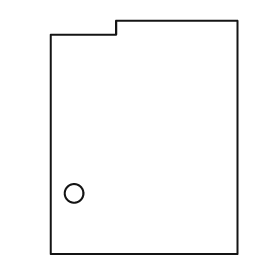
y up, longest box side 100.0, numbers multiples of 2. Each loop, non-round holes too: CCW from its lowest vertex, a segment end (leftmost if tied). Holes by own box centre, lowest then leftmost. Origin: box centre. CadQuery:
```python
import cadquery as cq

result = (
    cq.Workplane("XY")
    .moveTo(-40.0, -50.0)
    .lineTo(40.0, -50.0)
    .lineTo(40.0, 50.0)
    .lineTo(-12.0, 50.0)
    .lineTo(-12.0, 44.0)
    .lineTo(-40.0, 44.0)
    .close()
    .moveTo(-30.0, -24.0)
    .circle(4.0)
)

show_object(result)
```